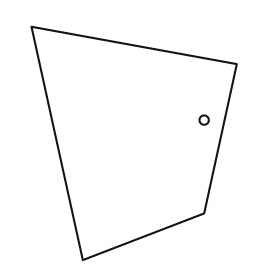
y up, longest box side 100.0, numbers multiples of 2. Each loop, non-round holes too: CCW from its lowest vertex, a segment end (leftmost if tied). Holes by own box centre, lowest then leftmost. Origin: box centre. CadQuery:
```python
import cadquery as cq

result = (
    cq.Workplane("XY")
    .moveTo(-22.0, -50.0)
    .lineTo(30.0, -30.0)
    .lineTo(44.0, 34.0)
    .lineTo(-44.0, 50.0)
    .close()
    .moveTo(30.0, 10.0)
    .circle(2.0)
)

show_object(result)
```